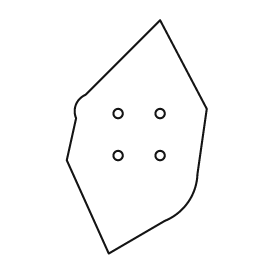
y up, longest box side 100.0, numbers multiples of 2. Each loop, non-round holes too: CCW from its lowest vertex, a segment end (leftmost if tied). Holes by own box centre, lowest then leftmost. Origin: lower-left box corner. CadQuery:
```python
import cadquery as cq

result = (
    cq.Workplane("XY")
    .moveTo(18.0, 0.0)
    .lineTo(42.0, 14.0)
    .threePointArc((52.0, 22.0), (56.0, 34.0))
    .lineTo(60.0, 62.0)
    .lineTo(40.0, 100.0)
    .lineTo(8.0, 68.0)
    .threePointArc((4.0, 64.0), (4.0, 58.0))
    .lineTo(0.0, 40.0)
    .close()
    .moveTo(22.0, 42.0)
    .circle(2.0)
    .moveTo(40.0, 42.0)
    .circle(2.0)
    .moveTo(22.0, 60.0)
    .circle(2.0)
    .moveTo(40.0, 60.0)
    .circle(2.0)
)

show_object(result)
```